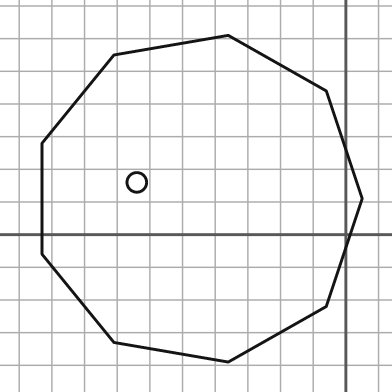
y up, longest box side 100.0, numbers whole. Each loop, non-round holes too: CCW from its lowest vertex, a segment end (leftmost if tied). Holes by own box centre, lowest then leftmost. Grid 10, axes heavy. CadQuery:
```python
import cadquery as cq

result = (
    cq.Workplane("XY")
    .moveTo(-36.0, -39.0)
    .lineTo(-6.0, -22.0)
    .lineTo(5.0, 11.0)
    .lineTo(-6.0, 44.0)
    .lineTo(-36.0, 61.0)
    .lineTo(-71.0, 55.0)
    .lineTo(-93.0, 28.0)
    .lineTo(-93.0, -6.0)
    .lineTo(-71.0, -33.0)
    .close()
    .moveTo(-64.0, 16.0)
    .circle(3.0)
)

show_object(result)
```